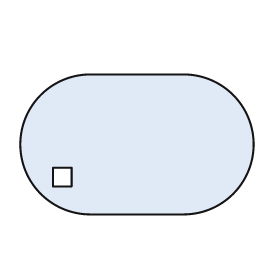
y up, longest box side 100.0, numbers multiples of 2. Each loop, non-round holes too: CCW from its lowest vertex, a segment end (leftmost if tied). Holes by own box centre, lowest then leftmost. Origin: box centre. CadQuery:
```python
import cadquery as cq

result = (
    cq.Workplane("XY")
    .moveTo(-20.0, -30.0)
    .lineTo(20.0, -30.0)
    .threePointArc((50.0, 0.0), (20.0, 30.0))
    .lineTo(-20.0, 30.0)
    .threePointArc((-50.0, 0.0), (-20.0, -30.0))
    .close()
    .moveTo(-36.0, -18.0)
    .lineTo(-28.0, -18.0)
    .lineTo(-28.0, -10.0)
    .lineTo(-36.0, -10.0)
    .close()
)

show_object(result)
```